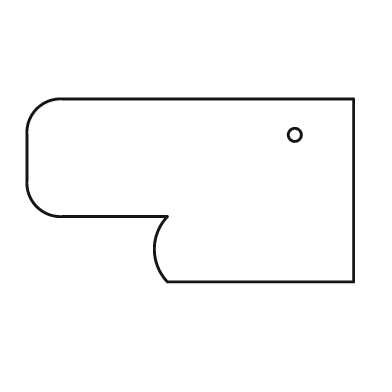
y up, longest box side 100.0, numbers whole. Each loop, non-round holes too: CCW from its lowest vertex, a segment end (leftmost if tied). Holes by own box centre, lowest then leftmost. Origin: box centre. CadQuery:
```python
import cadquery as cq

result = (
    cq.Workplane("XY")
    .moveTo(-7.0, -28.0)
    .lineTo(50.0, -28.0)
    .lineTo(50.0, 28.0)
    .lineTo(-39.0, 28.0)
    .threePointArc((-47.0, 25.0), (-50.0, 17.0))
    .lineTo(-50.0, 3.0)
    .threePointArc((-47.0, -5.0), (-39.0, -8.0))
    .lineTo(-7.0, -8.0)
    .threePointArc((-11.0, -18.0), (-7.0, -28.0))
    .close()
    .moveTo(32.0, 17.0)
    .circle(2.0)
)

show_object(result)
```